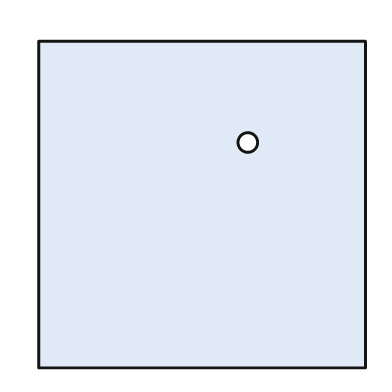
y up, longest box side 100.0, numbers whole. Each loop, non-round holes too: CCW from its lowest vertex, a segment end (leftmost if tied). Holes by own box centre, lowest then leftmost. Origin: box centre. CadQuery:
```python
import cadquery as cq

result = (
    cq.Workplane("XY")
    .moveTo(-50.0, -50.0)
    .lineTo(50.0, -50.0)
    .lineTo(50.0, 50.0)
    .lineTo(-50.0, 50.0)
    .close()
    .moveTo(14.0, 19.0)
    .circle(3.0)
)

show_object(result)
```